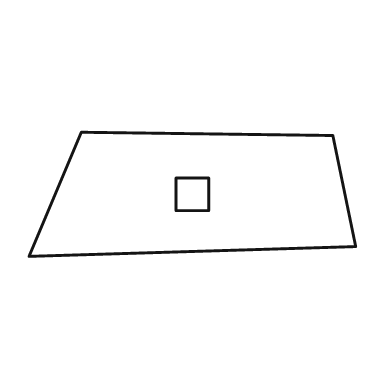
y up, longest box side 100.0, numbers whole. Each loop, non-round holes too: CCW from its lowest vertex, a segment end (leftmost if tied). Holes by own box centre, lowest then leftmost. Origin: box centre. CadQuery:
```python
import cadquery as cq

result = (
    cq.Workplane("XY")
    .moveTo(-50.0, -19.0)
    .lineTo(50.0, -16.0)
    .lineTo(43.0, 18.0)
    .lineTo(-34.0, 19.0)
    .close()
    .moveTo(-5.0, -5.0)
    .lineTo(5.0, -5.0)
    .lineTo(5.0, 5.0)
    .lineTo(-5.0, 5.0)
    .close()
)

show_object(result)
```